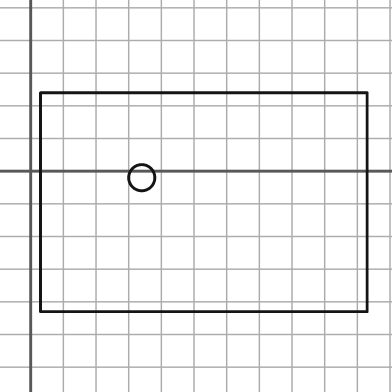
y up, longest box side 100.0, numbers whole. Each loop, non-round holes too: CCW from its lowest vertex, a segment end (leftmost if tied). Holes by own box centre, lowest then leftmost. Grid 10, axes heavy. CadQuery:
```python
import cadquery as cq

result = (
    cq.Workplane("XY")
    .moveTo(3.0, -43.0)
    .lineTo(103.0, -43.0)
    .lineTo(103.0, 24.0)
    .lineTo(3.0, 24.0)
    .close()
    .moveTo(34.0, -2.0)
    .circle(4.0)
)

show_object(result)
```